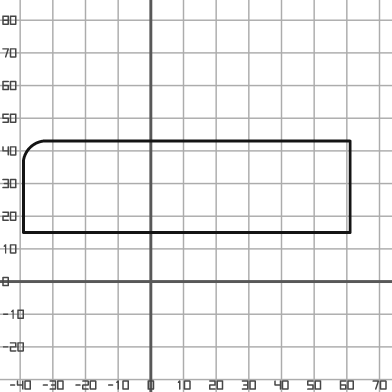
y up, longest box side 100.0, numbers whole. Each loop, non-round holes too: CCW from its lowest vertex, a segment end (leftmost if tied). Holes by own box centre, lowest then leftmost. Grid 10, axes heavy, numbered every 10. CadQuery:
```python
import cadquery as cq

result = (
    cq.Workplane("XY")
    .moveTo(-39.0, 15.0)
    .lineTo(61.0, 15.0)
    .lineTo(61.0, 43.0)
    .lineTo(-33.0, 43.0)
    .threePointArc((-37.0, 41.0), (-39.0, 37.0))
    .close()
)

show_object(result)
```